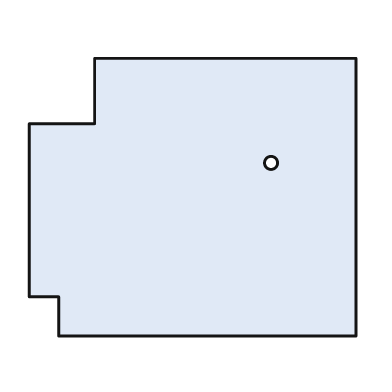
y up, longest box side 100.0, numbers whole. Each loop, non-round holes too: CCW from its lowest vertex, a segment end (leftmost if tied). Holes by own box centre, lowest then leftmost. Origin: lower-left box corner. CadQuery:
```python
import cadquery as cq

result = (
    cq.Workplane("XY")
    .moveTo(9.0, 0.0)
    .lineTo(100.0, 0.0)
    .lineTo(100.0, 85.0)
    .lineTo(20.0, 85.0)
    .lineTo(20.0, 65.0)
    .lineTo(0.0, 65.0)
    .lineTo(0.0, 12.0)
    .lineTo(9.0, 12.0)
    .close()
    .moveTo(74.0, 53.0)
    .circle(2.0)
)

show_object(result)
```